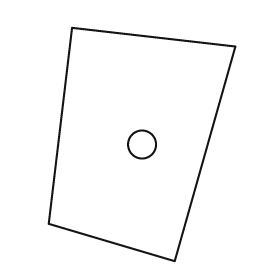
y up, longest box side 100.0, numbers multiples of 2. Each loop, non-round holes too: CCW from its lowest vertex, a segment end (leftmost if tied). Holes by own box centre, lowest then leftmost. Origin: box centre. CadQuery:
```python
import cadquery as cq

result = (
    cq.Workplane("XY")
    .moveTo(14.0, -50.0)
    .lineTo(40.0, 42.0)
    .lineTo(-30.0, 50.0)
    .lineTo(-40.0, -34.0)
    .close()
    .moveTo(0.0, 0.0)
    .circle(6.0)
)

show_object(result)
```